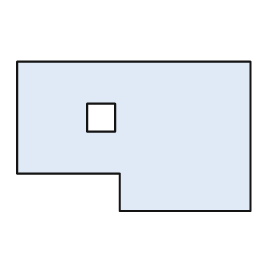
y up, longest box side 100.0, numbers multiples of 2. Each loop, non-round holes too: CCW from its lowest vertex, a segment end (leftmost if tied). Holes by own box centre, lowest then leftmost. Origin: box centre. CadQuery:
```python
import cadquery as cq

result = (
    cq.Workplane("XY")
    .moveTo(-6.0, -32.0)
    .lineTo(50.0, -32.0)
    .lineTo(50.0, 32.0)
    .lineTo(-50.0, 32.0)
    .lineTo(-50.0, -16.0)
    .lineTo(-6.0, -16.0)
    .close()
    .moveTo(-20.0, 2.0)
    .lineTo(-8.0, 2.0)
    .lineTo(-8.0, 14.0)
    .lineTo(-20.0, 14.0)
    .close()
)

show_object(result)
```